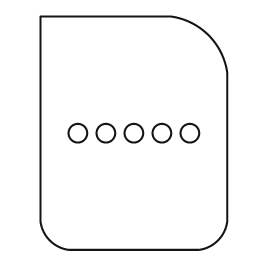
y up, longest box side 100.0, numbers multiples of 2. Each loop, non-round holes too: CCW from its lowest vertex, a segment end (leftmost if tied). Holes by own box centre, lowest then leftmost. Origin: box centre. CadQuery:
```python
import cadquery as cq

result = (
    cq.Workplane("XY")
    .moveTo(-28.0, -50.0)
    .lineTo(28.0, -50.0)
    .threePointArc((36.0, -46.0), (40.0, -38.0))
    .lineTo(40.0, 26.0)
    .threePointArc((32.0, 42.0), (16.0, 50.0))
    .lineTo(-40.0, 50.0)
    .lineTo(-40.0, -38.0)
    .threePointArc((-36.0, -46.0), (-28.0, -50.0))
    .close()
    .moveTo(-24.0, 0.0)
    .circle(4.0)
    .moveTo(-12.0, 0.0)
    .circle(4.0)
    .moveTo(0.0, 0.0)
    .circle(4.0)
    .moveTo(12.0, 0.0)
    .circle(4.0)
    .moveTo(24.0, 0.0)
    .circle(4.0)
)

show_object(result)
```